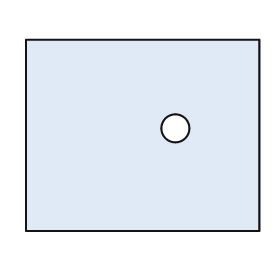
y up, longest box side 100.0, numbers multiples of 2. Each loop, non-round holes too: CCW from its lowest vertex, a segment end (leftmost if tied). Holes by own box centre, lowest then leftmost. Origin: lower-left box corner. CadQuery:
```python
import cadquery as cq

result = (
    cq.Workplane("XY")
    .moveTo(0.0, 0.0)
    .lineTo(100.0, 0.0)
    .lineTo(100.0, 82.0)
    .lineTo(0.0, 82.0)
    .close()
    .moveTo(64.0, 44.0)
    .circle(6.0)
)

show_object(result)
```